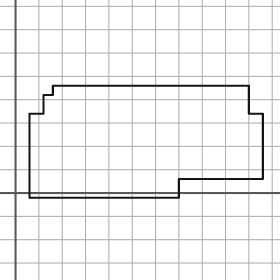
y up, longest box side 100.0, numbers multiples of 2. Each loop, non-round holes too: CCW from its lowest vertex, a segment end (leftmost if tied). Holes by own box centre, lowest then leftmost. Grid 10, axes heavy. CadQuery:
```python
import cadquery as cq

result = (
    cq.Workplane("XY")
    .moveTo(6.0, -2.0)
    .lineTo(70.0, -2.0)
    .lineTo(70.0, 6.0)
    .lineTo(106.0, 6.0)
    .lineTo(106.0, 34.0)
    .lineTo(100.0, 34.0)
    .lineTo(100.0, 46.0)
    .lineTo(16.0, 46.0)
    .lineTo(16.0, 42.0)
    .lineTo(12.0, 42.0)
    .lineTo(12.0, 34.0)
    .lineTo(6.0, 34.0)
    .close()
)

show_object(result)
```